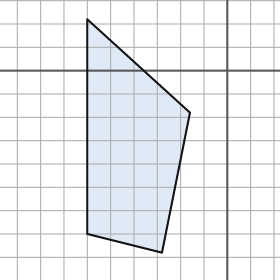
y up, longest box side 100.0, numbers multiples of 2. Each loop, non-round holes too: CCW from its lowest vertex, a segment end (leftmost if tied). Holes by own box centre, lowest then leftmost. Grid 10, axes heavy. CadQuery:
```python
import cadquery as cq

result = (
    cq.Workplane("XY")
    .moveTo(-28.0, -78.0)
    .lineTo(-16.0, -18.0)
    .lineTo(-60.0, 22.0)
    .lineTo(-60.0, -70.0)
    .close()
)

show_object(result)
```